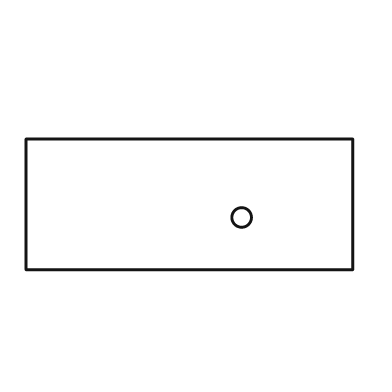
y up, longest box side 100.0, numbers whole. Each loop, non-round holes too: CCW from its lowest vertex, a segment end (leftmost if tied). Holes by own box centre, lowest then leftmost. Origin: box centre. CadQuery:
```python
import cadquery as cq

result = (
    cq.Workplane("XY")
    .moveTo(-50.0, -20.0)
    .lineTo(50.0, -20.0)
    .lineTo(50.0, 20.0)
    .lineTo(-50.0, 20.0)
    .close()
    .moveTo(16.0, -4.0)
    .circle(3.0)
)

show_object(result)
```